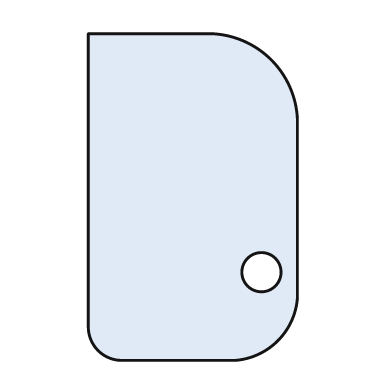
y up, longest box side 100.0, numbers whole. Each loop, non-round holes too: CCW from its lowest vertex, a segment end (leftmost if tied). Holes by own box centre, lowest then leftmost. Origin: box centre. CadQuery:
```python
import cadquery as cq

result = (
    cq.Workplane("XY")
    .moveTo(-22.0, -50.0)
    .lineTo(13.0, -50.0)
    .threePointArc((26.0, -44.0), (32.0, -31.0))
    .lineTo(32.0, 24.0)
    .threePointArc((24.0, 42.0), (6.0, 50.0))
    .lineTo(-32.0, 50.0)
    .lineTo(-32.0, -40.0)
    .threePointArc((-29.0, -47.0), (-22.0, -50.0))
    .close()
    .moveTo(21.0, -23.0)
    .circle(6.0)
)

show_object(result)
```